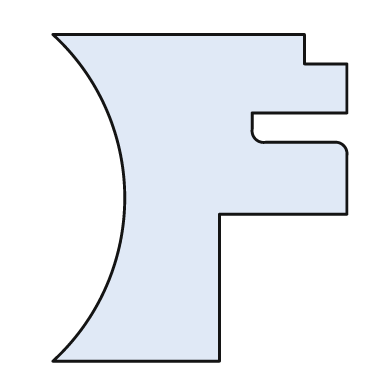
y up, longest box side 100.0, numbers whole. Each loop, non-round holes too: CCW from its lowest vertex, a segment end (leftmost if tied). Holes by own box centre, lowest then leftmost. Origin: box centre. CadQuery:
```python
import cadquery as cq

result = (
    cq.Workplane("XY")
    .moveTo(-45.0, -50.0)
    .lineTo(6.0, -50.0)
    .lineTo(6.0, -5.0)
    .lineTo(45.0, -5.0)
    .lineTo(45.0, 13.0)
    .threePointArc((44.0, 16.0), (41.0, 17.0))
    .lineTo(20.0, 17.0)
    .threePointArc((17.0, 18.0), (16.0, 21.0))
    .lineTo(16.0, 26.0)
    .lineTo(45.0, 26.0)
    .lineTo(45.0, 41.0)
    .lineTo(32.0, 41.0)
    .lineTo(32.0, 50.0)
    .lineTo(-45.0, 50.0)
    .threePointArc((-23.0, 0.0), (-45.0, -50.0))
    .close()
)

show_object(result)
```